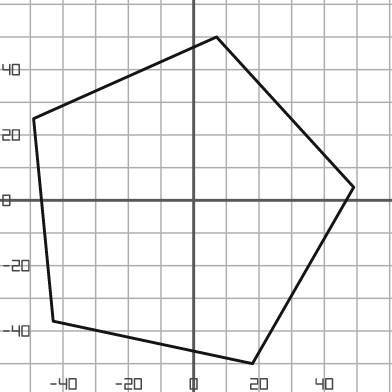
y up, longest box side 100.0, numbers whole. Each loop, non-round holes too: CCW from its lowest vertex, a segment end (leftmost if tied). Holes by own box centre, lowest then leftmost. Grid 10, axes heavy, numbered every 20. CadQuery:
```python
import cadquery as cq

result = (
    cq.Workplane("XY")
    .moveTo(18.0, -50.0)
    .lineTo(49.0, 4.0)
    .lineTo(7.0, 50.0)
    .lineTo(-49.0, 25.0)
    .lineTo(-43.0, -37.0)
    .close()
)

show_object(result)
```